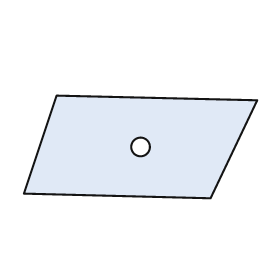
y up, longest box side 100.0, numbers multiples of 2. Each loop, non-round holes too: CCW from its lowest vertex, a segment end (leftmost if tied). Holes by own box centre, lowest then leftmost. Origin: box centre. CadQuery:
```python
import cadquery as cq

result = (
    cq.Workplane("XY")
    .moveTo(30.0, -22.0)
    .lineTo(50.0, 20.0)
    .lineTo(-36.0, 22.0)
    .lineTo(-50.0, -20.0)
    .close()
    .moveTo(0.0, 0.0)
    .circle(4.0)
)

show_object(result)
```